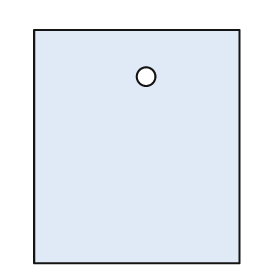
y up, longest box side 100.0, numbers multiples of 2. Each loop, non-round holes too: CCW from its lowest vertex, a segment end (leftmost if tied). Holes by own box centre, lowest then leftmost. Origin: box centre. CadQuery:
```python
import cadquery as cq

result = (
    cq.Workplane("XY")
    .moveTo(-44.0, -50.0)
    .lineTo(44.0, -50.0)
    .lineTo(44.0, 50.0)
    .lineTo(-44.0, 50.0)
    .close()
    .moveTo(4.0, 30.0)
    .circle(4.0)
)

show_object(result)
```